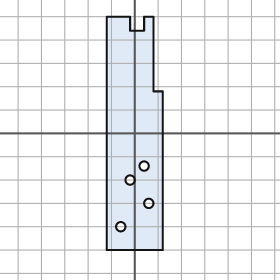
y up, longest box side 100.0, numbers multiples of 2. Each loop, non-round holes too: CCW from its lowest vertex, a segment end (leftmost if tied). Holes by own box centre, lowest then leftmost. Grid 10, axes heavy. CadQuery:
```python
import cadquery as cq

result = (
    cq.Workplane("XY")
    .moveTo(-12.0, -50.0)
    .lineTo(12.0, -50.0)
    .lineTo(12.0, 18.0)
    .lineTo(8.0, 18.0)
    .lineTo(8.0, 50.0)
    .lineTo(4.0, 50.0)
    .lineTo(4.0, 44.0)
    .lineTo(-2.0, 44.0)
    .lineTo(-2.0, 50.0)
    .lineTo(-12.0, 50.0)
    .close()
    .moveTo(-6.0, -40.0)
    .circle(2.0)
    .moveTo(6.0, -30.0)
    .circle(2.0)
    .moveTo(-2.0, -20.0)
    .circle(2.0)
    .moveTo(4.0, -14.0)
    .circle(2.0)
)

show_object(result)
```